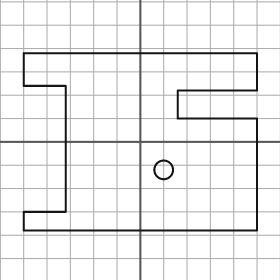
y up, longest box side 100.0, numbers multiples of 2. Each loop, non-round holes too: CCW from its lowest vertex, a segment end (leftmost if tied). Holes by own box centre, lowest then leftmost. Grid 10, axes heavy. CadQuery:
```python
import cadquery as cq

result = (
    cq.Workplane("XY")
    .moveTo(-50.0, -38.0)
    .lineTo(50.0, -38.0)
    .lineTo(50.0, 10.0)
    .lineTo(16.0, 10.0)
    .lineTo(16.0, 22.0)
    .lineTo(50.0, 22.0)
    .lineTo(50.0, 38.0)
    .lineTo(-50.0, 38.0)
    .lineTo(-50.0, 24.0)
    .lineTo(-32.0, 24.0)
    .lineTo(-32.0, -30.0)
    .lineTo(-50.0, -30.0)
    .close()
    .moveTo(10.0, -12.0)
    .circle(4.0)
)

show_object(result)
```